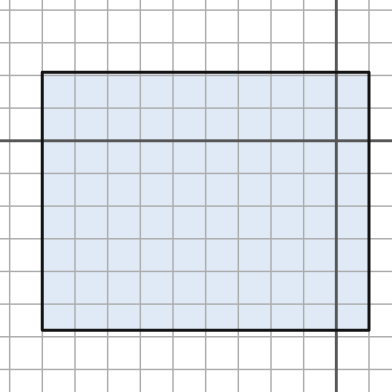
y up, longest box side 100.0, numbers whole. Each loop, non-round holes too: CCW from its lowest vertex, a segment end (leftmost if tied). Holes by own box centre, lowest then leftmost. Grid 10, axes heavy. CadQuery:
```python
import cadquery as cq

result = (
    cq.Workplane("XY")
    .moveTo(-90.0, -58.0)
    .lineTo(10.0, -58.0)
    .lineTo(10.0, 21.0)
    .lineTo(-90.0, 21.0)
    .close()
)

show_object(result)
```